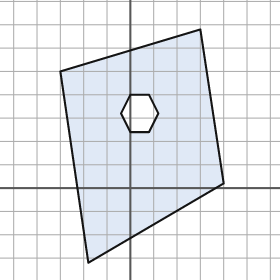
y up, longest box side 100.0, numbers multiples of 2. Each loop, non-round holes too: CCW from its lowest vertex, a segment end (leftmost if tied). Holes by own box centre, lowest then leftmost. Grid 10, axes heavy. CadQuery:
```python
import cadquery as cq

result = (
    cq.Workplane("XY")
    .moveTo(-18.0, -32.0)
    .lineTo(40.0, 2.0)
    .lineTo(30.0, 68.0)
    .lineTo(-30.0, 50.0)
    .close()
    .moveTo(0.0, 24.0)
    .lineTo(8.0, 24.0)
    .lineTo(12.0, 32.0)
    .lineTo(8.0, 40.0)
    .lineTo(0.0, 40.0)
    .lineTo(-4.0, 32.0)
    .close()
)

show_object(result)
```